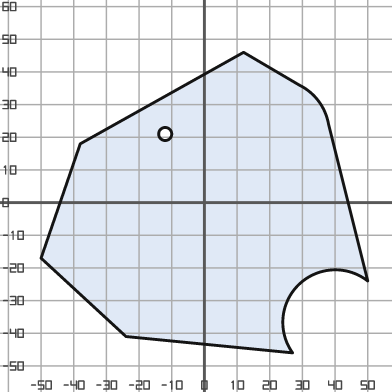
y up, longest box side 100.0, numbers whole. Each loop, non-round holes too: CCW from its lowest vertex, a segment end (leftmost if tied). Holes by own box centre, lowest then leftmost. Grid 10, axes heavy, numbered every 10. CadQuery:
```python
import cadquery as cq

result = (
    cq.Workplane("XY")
    .moveTo(27.0, -46.0)
    .threePointArc((29.0, -25.0), (50.0, -24.0))
    .lineTo(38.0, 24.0)
    .threePointArc((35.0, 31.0), (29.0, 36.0))
    .lineTo(12.0, 46.0)
    .lineTo(-38.0, 18.0)
    .lineTo(-50.0, -17.0)
    .lineTo(-24.0, -41.0)
    .close()
    .moveTo(-12.0, 21.0)
    .circle(2.0)
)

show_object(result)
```